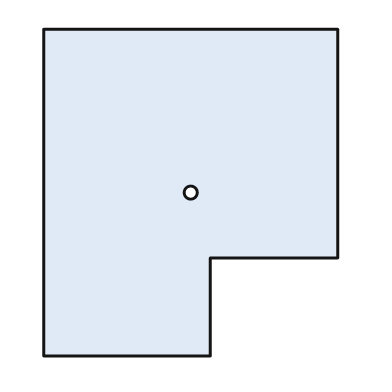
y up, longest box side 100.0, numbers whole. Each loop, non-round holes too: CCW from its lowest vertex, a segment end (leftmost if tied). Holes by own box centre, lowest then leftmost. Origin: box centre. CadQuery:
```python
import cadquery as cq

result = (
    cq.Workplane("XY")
    .moveTo(-45.0, -50.0)
    .lineTo(6.0, -50.0)
    .lineTo(6.0, -20.0)
    .lineTo(45.0, -20.0)
    .lineTo(45.0, 50.0)
    .lineTo(-45.0, 50.0)
    .close()
    .moveTo(0.0, 0.0)
    .circle(2.0)
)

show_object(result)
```